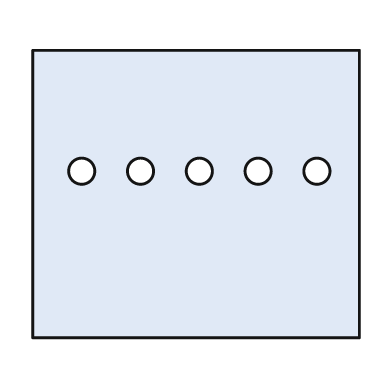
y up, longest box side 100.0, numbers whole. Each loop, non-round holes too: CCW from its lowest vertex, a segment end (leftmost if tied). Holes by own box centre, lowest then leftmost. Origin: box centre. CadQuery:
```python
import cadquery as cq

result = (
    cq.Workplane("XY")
    .moveTo(-50.0, -44.0)
    .lineTo(50.0, -44.0)
    .lineTo(50.0, 44.0)
    .lineTo(-50.0, 44.0)
    .close()
    .moveTo(-35.0, 7.0)
    .circle(4.0)
    .moveTo(-17.0, 7.0)
    .circle(4.0)
    .moveTo(1.0, 7.0)
    .circle(4.0)
    .moveTo(19.0, 7.0)
    .circle(4.0)
    .moveTo(37.0, 7.0)
    .circle(4.0)
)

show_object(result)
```